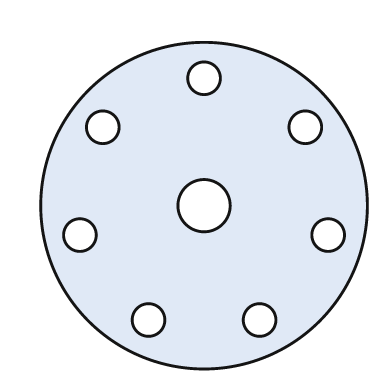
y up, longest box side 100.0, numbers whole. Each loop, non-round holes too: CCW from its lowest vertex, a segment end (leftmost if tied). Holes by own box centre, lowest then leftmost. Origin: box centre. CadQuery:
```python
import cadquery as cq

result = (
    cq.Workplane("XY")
    .moveTo(0.0, 0.0)
    .circle(50.0)
    .moveTo(-17.0, -35.0)
    .circle(5.0)
    .moveTo(17.0, -35.0)
    .circle(5.0)
    .moveTo(-38.0, -9.0)
    .circle(5.0)
    .moveTo(38.0, -9.0)
    .circle(5.0)
    .moveTo(0.0, 0.0)
    .circle(8.0)
    .moveTo(-31.0, 24.0)
    .circle(5.0)
    .moveTo(31.0, 24.0)
    .circle(5.0)
    .moveTo(0.0, 39.0)
    .circle(5.0)
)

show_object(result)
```